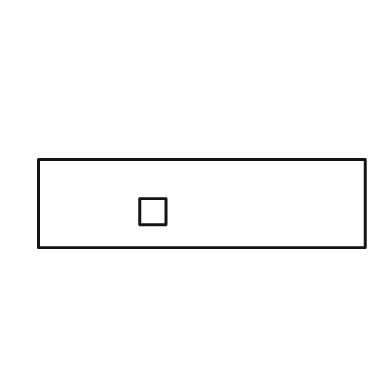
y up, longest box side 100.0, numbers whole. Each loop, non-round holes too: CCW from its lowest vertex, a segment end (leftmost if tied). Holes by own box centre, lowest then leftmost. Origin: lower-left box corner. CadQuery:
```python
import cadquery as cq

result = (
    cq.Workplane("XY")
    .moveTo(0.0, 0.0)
    .lineTo(100.0, 0.0)
    .lineTo(100.0, 27.0)
    .lineTo(0.0, 27.0)
    .close()
    .moveTo(31.0, 7.0)
    .lineTo(39.0, 7.0)
    .lineTo(39.0, 15.0)
    .lineTo(31.0, 15.0)
    .close()
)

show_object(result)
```